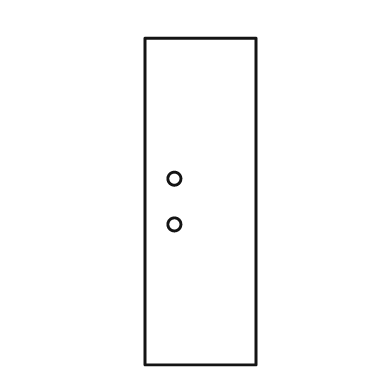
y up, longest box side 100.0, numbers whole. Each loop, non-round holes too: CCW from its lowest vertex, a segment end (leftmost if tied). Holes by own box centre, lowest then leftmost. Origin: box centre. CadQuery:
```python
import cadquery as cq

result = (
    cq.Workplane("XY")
    .moveTo(-17.0, -50.0)
    .lineTo(17.0, -50.0)
    .lineTo(17.0, 50.0)
    .lineTo(-17.0, 50.0)
    .close()
    .moveTo(-8.0, -7.0)
    .circle(2.0)
    .moveTo(-8.0, 7.0)
    .circle(2.0)
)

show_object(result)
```